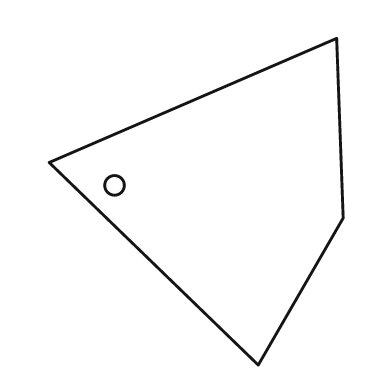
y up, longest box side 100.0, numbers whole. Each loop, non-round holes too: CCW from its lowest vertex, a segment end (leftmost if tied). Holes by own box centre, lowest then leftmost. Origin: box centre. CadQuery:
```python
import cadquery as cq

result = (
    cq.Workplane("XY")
    .moveTo(19.0, -50.0)
    .lineTo(45.0, -5.0)
    .lineTo(43.0, 50.0)
    .lineTo(-45.0, 12.0)
    .close()
    .moveTo(-25.0, 5.0)
    .circle(3.0)
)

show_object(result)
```